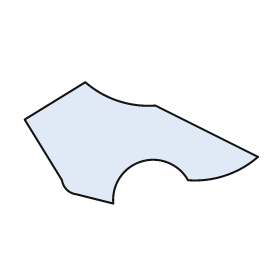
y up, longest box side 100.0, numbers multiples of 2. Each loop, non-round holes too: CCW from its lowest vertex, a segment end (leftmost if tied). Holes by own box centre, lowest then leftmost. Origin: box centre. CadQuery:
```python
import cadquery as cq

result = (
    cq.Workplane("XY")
    .moveTo(-12.0, -26.0)
    .threePointArc((0.0, -8.0), (20.0, -16.0))
    .threePointArc((36.0, -14.0), (50.0, -6.0))
    .lineTo(6.0, 16.0)
    .threePointArc((-10.0, 18.0), (-24.0, 26.0))
    .lineTo(-50.0, 10.0)
    .lineTo(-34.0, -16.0)
    .threePointArc((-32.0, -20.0), (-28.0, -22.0))
    .close()
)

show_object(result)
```